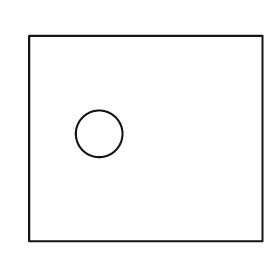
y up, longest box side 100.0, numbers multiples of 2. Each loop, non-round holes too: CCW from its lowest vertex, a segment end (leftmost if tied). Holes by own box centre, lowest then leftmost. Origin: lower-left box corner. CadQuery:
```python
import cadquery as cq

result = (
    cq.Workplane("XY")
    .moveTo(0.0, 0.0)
    .lineTo(100.0, 0.0)
    .lineTo(100.0, 88.0)
    .lineTo(0.0, 88.0)
    .close()
    .moveTo(30.0, 46.0)
    .circle(10.0)
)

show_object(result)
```